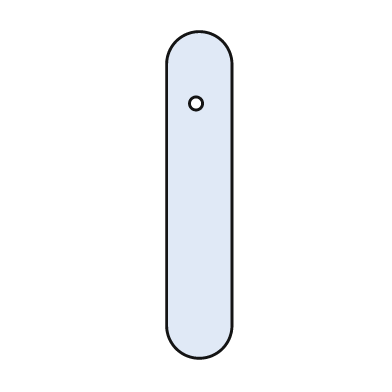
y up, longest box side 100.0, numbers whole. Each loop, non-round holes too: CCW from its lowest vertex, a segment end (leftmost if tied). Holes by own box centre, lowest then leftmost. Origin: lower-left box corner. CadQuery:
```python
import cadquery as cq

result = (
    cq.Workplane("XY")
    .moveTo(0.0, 10.0)
    .threePointArc((10.0, 0.0), (20.0, 10.0))
    .lineTo(20.0, 90.0)
    .threePointArc((10.0, 100.0), (0.0, 90.0))
    .close()
    .moveTo(9.0, 78.0)
    .circle(2.0)
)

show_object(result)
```